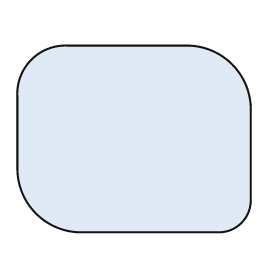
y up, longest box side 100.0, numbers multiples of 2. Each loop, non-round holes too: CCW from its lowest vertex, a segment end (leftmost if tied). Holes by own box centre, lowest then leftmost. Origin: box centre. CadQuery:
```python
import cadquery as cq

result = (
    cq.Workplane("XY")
    .moveTo(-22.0, -40.0)
    .lineTo(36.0, -40.0)
    .threePointArc((46.0, -36.0), (50.0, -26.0))
    .lineTo(50.0, 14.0)
    .threePointArc((42.0, 32.0), (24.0, 40.0))
    .lineTo(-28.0, 40.0)
    .threePointArc((-44.0, 34.0), (-50.0, 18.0))
    .lineTo(-50.0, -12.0)
    .threePointArc((-42.0, -32.0), (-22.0, -40.0))
    .close()
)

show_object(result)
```